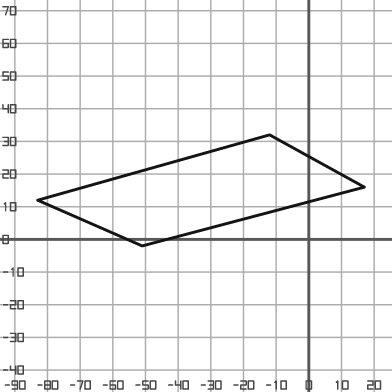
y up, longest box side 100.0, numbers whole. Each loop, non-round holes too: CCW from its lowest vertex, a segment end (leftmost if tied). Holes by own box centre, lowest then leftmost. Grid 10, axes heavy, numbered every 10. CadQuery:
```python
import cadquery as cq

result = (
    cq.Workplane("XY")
    .moveTo(-51.0, -2.0)
    .lineTo(17.0, 16.0)
    .lineTo(-12.0, 32.0)
    .lineTo(-83.0, 12.0)
    .close()
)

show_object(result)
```